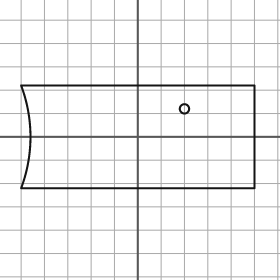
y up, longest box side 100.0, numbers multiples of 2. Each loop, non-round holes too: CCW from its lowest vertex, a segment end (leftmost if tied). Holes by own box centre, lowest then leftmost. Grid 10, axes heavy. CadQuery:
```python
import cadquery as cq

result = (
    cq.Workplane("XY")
    .moveTo(-50.0, -22.0)
    .lineTo(50.0, -22.0)
    .lineTo(50.0, 22.0)
    .lineTo(-50.0, 22.0)
    .threePointArc((-46.0, 0.0), (-50.0, -22.0))
    .close()
    .moveTo(20.0, 12.0)
    .circle(2.0)
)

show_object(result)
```